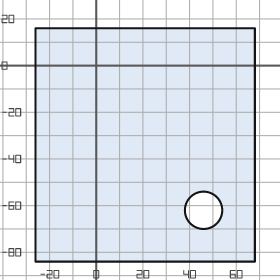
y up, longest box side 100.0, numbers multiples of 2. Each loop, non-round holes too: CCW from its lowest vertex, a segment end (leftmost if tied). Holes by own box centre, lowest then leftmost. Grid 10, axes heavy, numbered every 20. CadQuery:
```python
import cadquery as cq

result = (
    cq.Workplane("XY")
    .moveTo(-26.0, -84.0)
    .lineTo(68.0, -84.0)
    .lineTo(68.0, 16.0)
    .lineTo(-26.0, 16.0)
    .close()
    .moveTo(46.0, -62.0)
    .circle(8.0)
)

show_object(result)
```